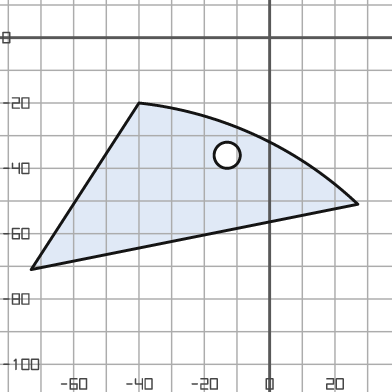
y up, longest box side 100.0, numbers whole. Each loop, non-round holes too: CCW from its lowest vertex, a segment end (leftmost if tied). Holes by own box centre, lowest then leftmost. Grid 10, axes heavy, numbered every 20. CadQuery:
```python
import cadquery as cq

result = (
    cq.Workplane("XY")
    .moveTo(-73.0, -71.0)
    .lineTo(27.0, -51.0)
    .threePointArc((-4.0, -30.0), (-40.0, -20.0))
    .close()
    .moveTo(-13.0, -36.0)
    .circle(4.0)
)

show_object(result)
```